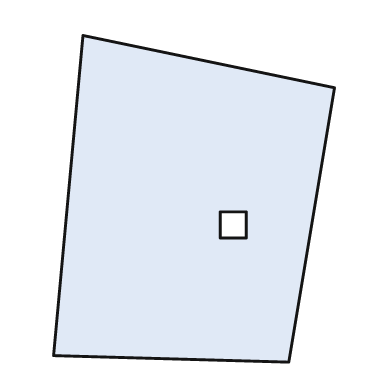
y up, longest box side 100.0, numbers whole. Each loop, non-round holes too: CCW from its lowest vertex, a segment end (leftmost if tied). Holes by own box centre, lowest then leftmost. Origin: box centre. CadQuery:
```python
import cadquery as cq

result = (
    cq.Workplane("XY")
    .moveTo(29.0, -50.0)
    .lineTo(43.0, 34.0)
    .lineTo(-34.0, 50.0)
    .lineTo(-43.0, -48.0)
    .close()
    .moveTo(8.0, -12.0)
    .lineTo(16.0, -12.0)
    .lineTo(16.0, -4.0)
    .lineTo(8.0, -4.0)
    .close()
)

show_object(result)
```